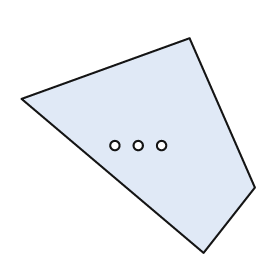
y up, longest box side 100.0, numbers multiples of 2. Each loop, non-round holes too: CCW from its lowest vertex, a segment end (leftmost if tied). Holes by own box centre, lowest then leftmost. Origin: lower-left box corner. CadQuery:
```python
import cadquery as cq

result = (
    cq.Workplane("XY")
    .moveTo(78.0, 0.0)
    .lineTo(100.0, 28.0)
    .lineTo(72.0, 92.0)
    .lineTo(0.0, 66.0)
    .close()
    .moveTo(40.0, 46.0)
    .circle(2.0)
    .moveTo(50.0, 46.0)
    .circle(2.0)
    .moveTo(60.0, 46.0)
    .circle(2.0)
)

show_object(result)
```